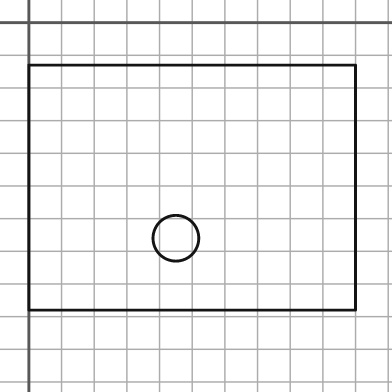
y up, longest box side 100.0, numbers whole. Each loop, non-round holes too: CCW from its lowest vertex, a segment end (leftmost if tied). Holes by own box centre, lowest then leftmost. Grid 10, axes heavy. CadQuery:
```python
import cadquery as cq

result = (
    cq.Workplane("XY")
    .moveTo(0.0, -88.0)
    .lineTo(100.0, -88.0)
    .lineTo(100.0, -13.0)
    .lineTo(0.0, -13.0)
    .close()
    .moveTo(45.0, -66.0)
    .circle(7.0)
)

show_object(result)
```